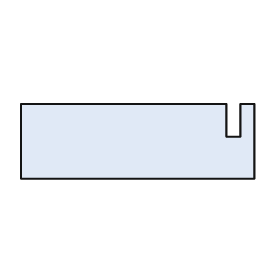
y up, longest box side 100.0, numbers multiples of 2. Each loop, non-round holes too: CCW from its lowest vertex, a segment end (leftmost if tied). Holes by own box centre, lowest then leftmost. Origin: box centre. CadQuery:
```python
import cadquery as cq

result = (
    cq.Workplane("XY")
    .moveTo(-50.0, -16.0)
    .lineTo(50.0, -16.0)
    .lineTo(50.0, 16.0)
    .lineTo(44.0, 16.0)
    .lineTo(44.0, 2.0)
    .lineTo(38.0, 2.0)
    .lineTo(38.0, 16.0)
    .lineTo(-50.0, 16.0)
    .close()
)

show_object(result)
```